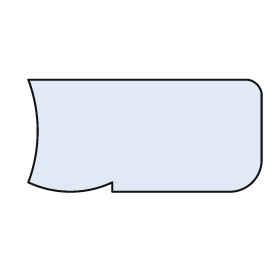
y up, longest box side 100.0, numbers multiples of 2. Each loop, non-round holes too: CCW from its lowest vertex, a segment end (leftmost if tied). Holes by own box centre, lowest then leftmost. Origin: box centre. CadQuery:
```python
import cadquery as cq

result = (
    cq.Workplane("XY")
    .moveTo(-14.0, -24.0)
    .lineTo(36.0, -24.0)
    .threePointArc((46.0, -20.0), (50.0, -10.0))
    .lineTo(50.0, 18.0)
    .threePointArc((48.0, 22.0), (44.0, 24.0))
    .lineTo(-50.0, 24.0)
    .threePointArc((-46.0, 2.0), (-50.0, -20.0))
    .threePointArc((-32.0, -24.0), (-14.0, -20.0))
    .close()
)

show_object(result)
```